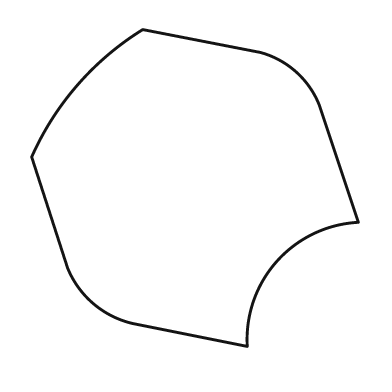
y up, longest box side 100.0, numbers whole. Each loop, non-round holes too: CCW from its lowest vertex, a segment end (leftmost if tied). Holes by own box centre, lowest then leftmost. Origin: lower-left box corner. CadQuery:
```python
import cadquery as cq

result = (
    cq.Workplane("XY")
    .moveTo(66.0, 0.0)
    .threePointArc((75.0, 26.0), (100.0, 38.0))
    .lineTo(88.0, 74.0)
    .threePointArc((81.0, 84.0), (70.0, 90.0))
    .lineTo(34.0, 97.0)
    .threePointArc((14.0, 80.0), (0.0, 58.0))
    .lineTo(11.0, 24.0)
    .threePointArc((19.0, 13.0), (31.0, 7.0))
    .close()
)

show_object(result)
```